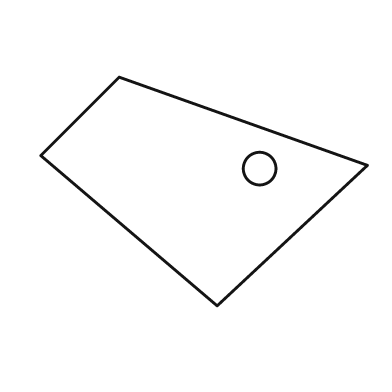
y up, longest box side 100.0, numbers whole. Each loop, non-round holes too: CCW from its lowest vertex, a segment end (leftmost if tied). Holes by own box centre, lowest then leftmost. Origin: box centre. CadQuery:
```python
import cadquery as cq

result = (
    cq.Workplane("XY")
    .moveTo(4.0, -35.0)
    .lineTo(50.0, 8.0)
    .lineTo(-26.0, 35.0)
    .lineTo(-50.0, 11.0)
    .close()
    .moveTo(17.0, 7.0)
    .circle(5.0)
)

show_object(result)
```